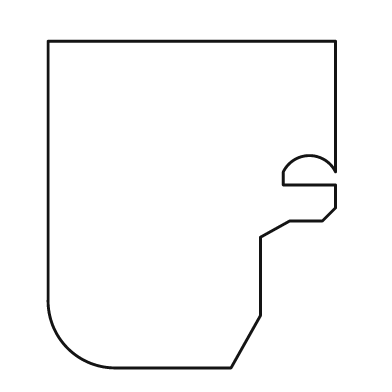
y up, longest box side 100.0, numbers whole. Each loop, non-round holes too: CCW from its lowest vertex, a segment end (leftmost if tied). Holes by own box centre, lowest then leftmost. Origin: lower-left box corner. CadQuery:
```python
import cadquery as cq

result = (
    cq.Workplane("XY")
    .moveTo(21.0, 0.0)
    .lineTo(56.0, 0.0)
    .lineTo(65.0, 16.0)
    .lineTo(65.0, 40.0)
    .lineTo(74.0, 45.0)
    .lineTo(84.0, 45.0)
    .lineTo(88.0, 49.0)
    .lineTo(88.0, 56.0)
    .lineTo(72.0, 56.0)
    .lineTo(72.0, 60.0)
    .threePointArc((80.0, 65.0), (88.0, 60.0))
    .lineTo(88.0, 100.0)
    .lineTo(0.0, 100.0)
    .lineTo(0.0, 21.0)
    .threePointArc((6.0, 6.0), (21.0, 0.0))
    .close()
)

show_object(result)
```